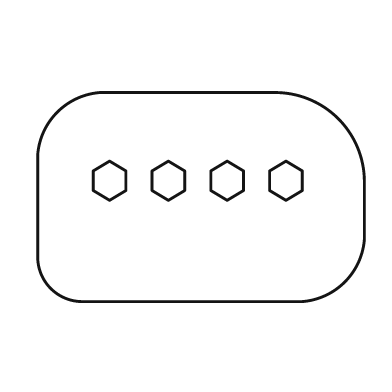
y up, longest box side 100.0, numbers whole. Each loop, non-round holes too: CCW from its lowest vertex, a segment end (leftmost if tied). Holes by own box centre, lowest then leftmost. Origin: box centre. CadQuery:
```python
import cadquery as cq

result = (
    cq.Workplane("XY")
    .moveTo(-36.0, -32.0)
    .lineTo(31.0, -32.0)
    .threePointArc((44.0, -26.0), (50.0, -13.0))
    .lineTo(50.0, 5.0)
    .threePointArc((42.0, 24.0), (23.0, 32.0))
    .lineTo(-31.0, 32.0)
    .threePointArc((-44.0, 26.0), (-50.0, 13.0))
    .lineTo(-50.0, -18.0)
    .threePointArc((-46.0, -28.0), (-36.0, -32.0))
    .close()
    .moveTo(-28.0, -1.0)
    .lineTo(-23.0, 2.0)
    .lineTo(-23.0, 8.0)
    .lineTo(-28.0, 11.0)
    .lineTo(-33.0, 8.0)
    .lineTo(-33.0, 2.0)
    .close()
    .moveTo(-10.0, -1.0)
    .lineTo(-5.0, 2.0)
    .lineTo(-5.0, 8.0)
    .lineTo(-10.0, 11.0)
    .lineTo(-15.0, 8.0)
    .lineTo(-15.0, 2.0)
    .close()
    .moveTo(8.0, -1.0)
    .lineTo(13.0, 2.0)
    .lineTo(13.0, 8.0)
    .lineTo(8.0, 11.0)
    .lineTo(3.0, 8.0)
    .lineTo(3.0, 2.0)
    .close()
    .moveTo(26.0, -1.0)
    .lineTo(31.0, 2.0)
    .lineTo(31.0, 8.0)
    .lineTo(26.0, 11.0)
    .lineTo(21.0, 8.0)
    .lineTo(21.0, 2.0)
    .close()
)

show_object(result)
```